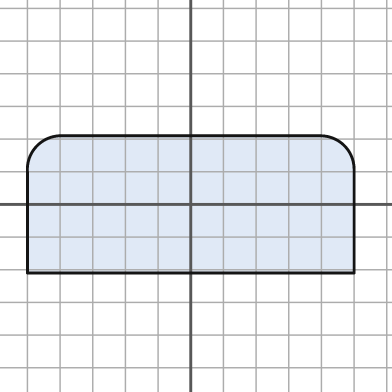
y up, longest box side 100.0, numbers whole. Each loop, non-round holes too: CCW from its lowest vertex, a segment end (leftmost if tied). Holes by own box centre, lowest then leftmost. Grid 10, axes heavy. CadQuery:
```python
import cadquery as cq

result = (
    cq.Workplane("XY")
    .moveTo(-50.0, -21.0)
    .lineTo(50.0, -21.0)
    .lineTo(50.0, 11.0)
    .threePointArc((47.0, 18.0), (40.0, 21.0))
    .lineTo(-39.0, 21.0)
    .threePointArc((-47.0, 18.0), (-50.0, 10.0))
    .close()
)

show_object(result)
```